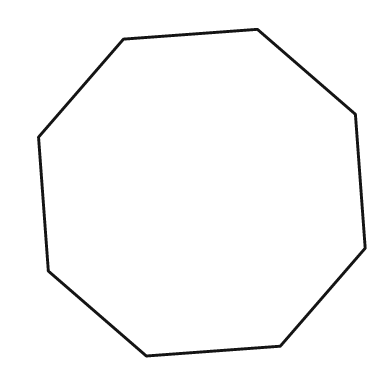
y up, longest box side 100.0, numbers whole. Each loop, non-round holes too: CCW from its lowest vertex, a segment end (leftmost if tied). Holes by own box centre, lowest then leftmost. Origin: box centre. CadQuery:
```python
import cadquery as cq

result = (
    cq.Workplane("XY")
    .moveTo(-17.0, -50.0)
    .lineTo(24.0, -47.0)
    .lineTo(50.0, -17.0)
    .lineTo(47.0, 24.0)
    .lineTo(17.0, 50.0)
    .lineTo(-24.0, 47.0)
    .lineTo(-50.0, 17.0)
    .lineTo(-47.0, -24.0)
    .close()
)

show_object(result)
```